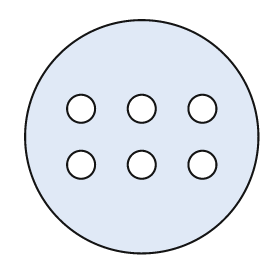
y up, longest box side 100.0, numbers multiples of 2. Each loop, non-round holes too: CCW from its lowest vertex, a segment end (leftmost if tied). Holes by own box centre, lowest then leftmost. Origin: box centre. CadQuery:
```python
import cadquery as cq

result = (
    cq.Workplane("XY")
    .moveTo(0.0, 0.0)
    .circle(50.0)
    .moveTo(-26.0, -12.0)
    .circle(6.0)
    .moveTo(0.0, -12.0)
    .circle(6.0)
    .moveTo(26.0, -12.0)
    .circle(6.0)
    .moveTo(-26.0, 12.0)
    .circle(6.0)
    .moveTo(0.0, 12.0)
    .circle(6.0)
    .moveTo(26.0, 12.0)
    .circle(6.0)
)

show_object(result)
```